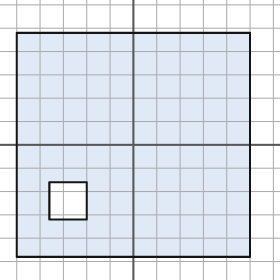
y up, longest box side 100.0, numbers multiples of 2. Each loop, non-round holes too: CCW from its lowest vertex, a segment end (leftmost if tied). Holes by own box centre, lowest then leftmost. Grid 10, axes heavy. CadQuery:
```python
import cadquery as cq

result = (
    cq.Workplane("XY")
    .moveTo(-50.0, -48.0)
    .lineTo(50.0, -48.0)
    .lineTo(50.0, 48.0)
    .lineTo(-50.0, 48.0)
    .close()
    .moveTo(-36.0, -32.0)
    .lineTo(-20.0, -32.0)
    .lineTo(-20.0, -16.0)
    .lineTo(-36.0, -16.0)
    .close()
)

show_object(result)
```